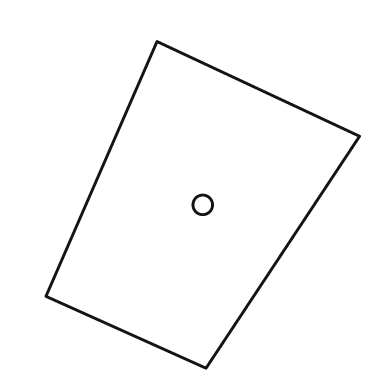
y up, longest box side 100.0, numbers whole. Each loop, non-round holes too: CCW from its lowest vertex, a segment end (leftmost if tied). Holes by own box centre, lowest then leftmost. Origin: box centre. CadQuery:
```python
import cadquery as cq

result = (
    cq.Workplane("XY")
    .moveTo(1.0, -50.0)
    .lineTo(48.0, 21.0)
    .lineTo(-14.0, 50.0)
    .lineTo(-48.0, -28.0)
    .close()
    .moveTo(0.0, 0.0)
    .circle(3.0)
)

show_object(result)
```